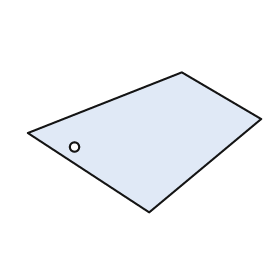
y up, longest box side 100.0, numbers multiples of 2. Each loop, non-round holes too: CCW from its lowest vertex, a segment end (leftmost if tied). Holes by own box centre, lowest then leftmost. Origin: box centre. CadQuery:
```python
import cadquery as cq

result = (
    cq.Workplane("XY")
    .moveTo(2.0, -30.0)
    .lineTo(50.0, 10.0)
    .lineTo(16.0, 30.0)
    .lineTo(-50.0, 4.0)
    .close()
    .moveTo(-30.0, -2.0)
    .circle(2.0)
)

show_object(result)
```